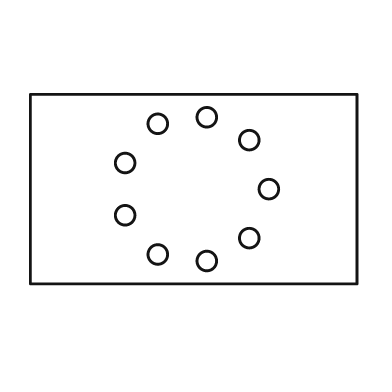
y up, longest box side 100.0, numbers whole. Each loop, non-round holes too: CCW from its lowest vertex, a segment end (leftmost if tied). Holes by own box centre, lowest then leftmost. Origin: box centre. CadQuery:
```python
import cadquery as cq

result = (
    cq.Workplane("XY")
    .moveTo(-50.0, -29.0)
    .lineTo(50.0, -29.0)
    .lineTo(50.0, 29.0)
    .lineTo(-50.0, 29.0)
    .close()
    .moveTo(4.0, -22.0)
    .circle(3.0)
    .moveTo(-11.0, -20.0)
    .circle(3.0)
    .moveTo(17.0, -15.0)
    .circle(3.0)
    .moveTo(-21.0, -8.0)
    .circle(3.0)
    .moveTo(23.0, 0.0)
    .circle(3.0)
    .moveTo(-21.0, 8.0)
    .circle(3.0)
    .moveTo(17.0, 15.0)
    .circle(3.0)
    .moveTo(-11.0, 20.0)
    .circle(3.0)
    .moveTo(4.0, 22.0)
    .circle(3.0)
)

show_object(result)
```